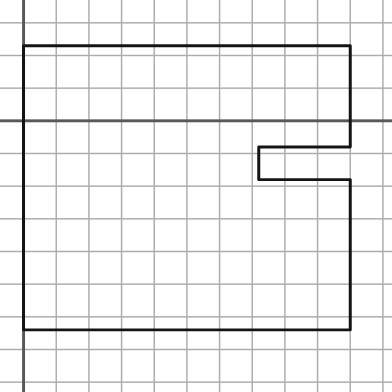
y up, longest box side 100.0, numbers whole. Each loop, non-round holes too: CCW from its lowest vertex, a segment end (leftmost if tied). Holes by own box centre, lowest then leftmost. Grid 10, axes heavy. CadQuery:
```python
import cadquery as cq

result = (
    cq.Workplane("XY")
    .moveTo(0.0, -64.0)
    .lineTo(100.0, -64.0)
    .lineTo(100.0, -18.0)
    .lineTo(72.0, -18.0)
    .lineTo(72.0, -8.0)
    .lineTo(100.0, -8.0)
    .lineTo(100.0, 23.0)
    .lineTo(0.0, 23.0)
    .close()
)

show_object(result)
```